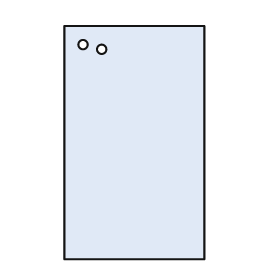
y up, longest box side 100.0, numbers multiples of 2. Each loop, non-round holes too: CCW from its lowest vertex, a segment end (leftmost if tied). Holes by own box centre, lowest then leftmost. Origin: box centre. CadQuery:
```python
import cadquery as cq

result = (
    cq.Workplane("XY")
    .moveTo(-30.0, -50.0)
    .lineTo(30.0, -50.0)
    .lineTo(30.0, 50.0)
    .lineTo(-30.0, 50.0)
    .close()
    .moveTo(-14.0, 40.0)
    .circle(2.0)
    .moveTo(-22.0, 42.0)
    .circle(2.0)
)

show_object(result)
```